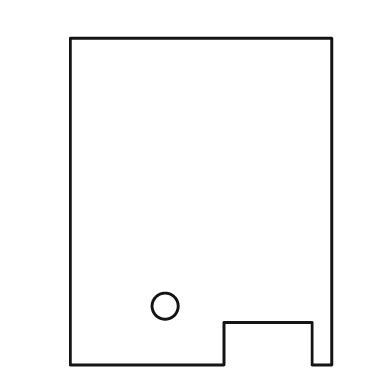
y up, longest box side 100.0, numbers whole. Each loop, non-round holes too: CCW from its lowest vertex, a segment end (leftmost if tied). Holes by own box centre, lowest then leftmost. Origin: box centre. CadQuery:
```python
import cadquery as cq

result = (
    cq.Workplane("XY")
    .moveTo(-40.0, -50.0)
    .lineTo(7.0, -50.0)
    .lineTo(7.0, -37.0)
    .lineTo(34.0, -37.0)
    .lineTo(34.0, -50.0)
    .lineTo(40.0, -50.0)
    .lineTo(40.0, 50.0)
    .lineTo(-40.0, 50.0)
    .close()
    .moveTo(-11.0, -32.0)
    .circle(4.0)
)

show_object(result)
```